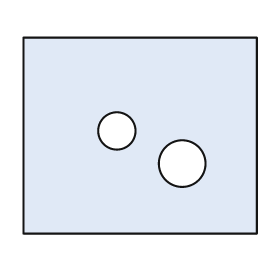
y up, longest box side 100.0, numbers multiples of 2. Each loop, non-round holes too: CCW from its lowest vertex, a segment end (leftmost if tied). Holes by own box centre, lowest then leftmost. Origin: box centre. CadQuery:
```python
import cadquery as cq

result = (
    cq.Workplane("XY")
    .moveTo(-50.0, -42.0)
    .lineTo(50.0, -42.0)
    .lineTo(50.0, 42.0)
    .lineTo(-50.0, 42.0)
    .close()
    .moveTo(18.0, -12.0)
    .circle(10.0)
    .moveTo(-10.0, 2.0)
    .circle(8.0)
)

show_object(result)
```